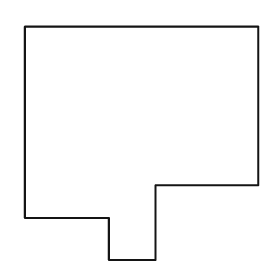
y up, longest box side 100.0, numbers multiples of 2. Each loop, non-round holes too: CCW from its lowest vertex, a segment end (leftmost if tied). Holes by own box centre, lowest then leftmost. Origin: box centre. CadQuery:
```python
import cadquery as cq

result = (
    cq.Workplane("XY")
    .moveTo(-14.0, -50.0)
    .lineTo(6.0, -50.0)
    .lineTo(6.0, -18.0)
    .lineTo(50.0, -18.0)
    .lineTo(50.0, 50.0)
    .lineTo(-50.0, 50.0)
    .lineTo(-50.0, -32.0)
    .lineTo(-14.0, -32.0)
    .close()
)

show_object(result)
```